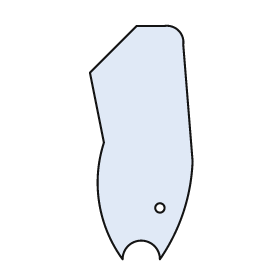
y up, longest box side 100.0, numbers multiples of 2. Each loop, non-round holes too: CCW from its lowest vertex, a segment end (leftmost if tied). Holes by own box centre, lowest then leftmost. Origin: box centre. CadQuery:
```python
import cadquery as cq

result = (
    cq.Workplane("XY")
    .moveTo(-8.0, -50.0)
    .threePointArc((0.0, -42.0), (8.0, -50.0))
    .threePointArc((18.0, -30.0), (22.0, -8.0))
    .lineTo(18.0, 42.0)
    .threePointArc((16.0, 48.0), (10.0, 50.0))
    .lineTo(-2.0, 50.0)
    .lineTo(-22.0, 30.0)
    .lineTo(-16.0, 0.0)
    .threePointArc((-18.0, -26.0), (-8.0, -50.0))
    .close()
    .moveTo(8.0, -28.0)
    .circle(2.0)
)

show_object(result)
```